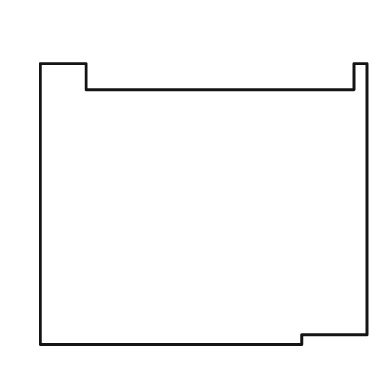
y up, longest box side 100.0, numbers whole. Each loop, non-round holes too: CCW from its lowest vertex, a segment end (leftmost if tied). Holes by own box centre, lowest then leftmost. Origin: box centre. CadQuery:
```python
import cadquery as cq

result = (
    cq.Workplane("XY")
    .moveTo(-50.0, -43.0)
    .lineTo(30.0, -43.0)
    .lineTo(30.0, -40.0)
    .lineTo(50.0, -40.0)
    .lineTo(50.0, 43.0)
    .lineTo(46.0, 43.0)
    .lineTo(46.0, 35.0)
    .lineTo(-36.0, 35.0)
    .lineTo(-36.0, 43.0)
    .lineTo(-50.0, 43.0)
    .close()
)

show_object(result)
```